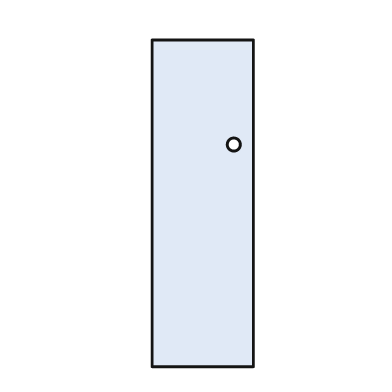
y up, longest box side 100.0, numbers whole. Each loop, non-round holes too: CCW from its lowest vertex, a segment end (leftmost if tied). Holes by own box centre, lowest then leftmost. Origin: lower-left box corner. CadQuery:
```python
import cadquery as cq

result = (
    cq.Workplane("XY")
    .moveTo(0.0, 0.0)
    .lineTo(31.0, 0.0)
    .lineTo(31.0, 100.0)
    .lineTo(0.0, 100.0)
    .close()
    .moveTo(25.0, 68.0)
    .circle(2.0)
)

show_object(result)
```